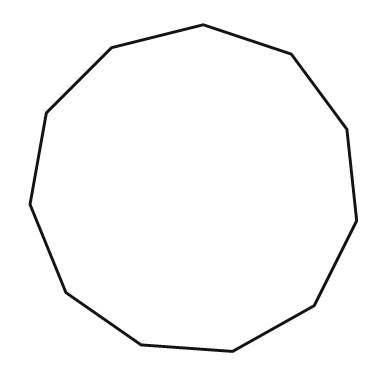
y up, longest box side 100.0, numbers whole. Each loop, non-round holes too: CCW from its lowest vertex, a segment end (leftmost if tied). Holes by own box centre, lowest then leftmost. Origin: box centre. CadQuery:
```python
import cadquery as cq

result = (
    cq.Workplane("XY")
    .moveTo(12.0, -50.0)
    .lineTo(37.0, -36.0)
    .lineTo(50.0, -10.0)
    .lineTo(47.0, 18.0)
    .lineTo(30.0, 41.0)
    .lineTo(3.0, 50.0)
    .lineTo(-25.0, 43.0)
    .lineTo(-45.0, 23.0)
    .lineTo(-50.0, -5.0)
    .lineTo(-39.0, -32.0)
    .lineTo(-16.0, -48.0)
    .close()
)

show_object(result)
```